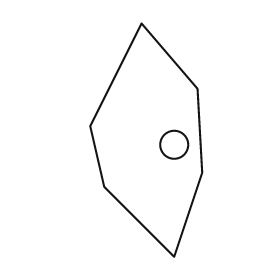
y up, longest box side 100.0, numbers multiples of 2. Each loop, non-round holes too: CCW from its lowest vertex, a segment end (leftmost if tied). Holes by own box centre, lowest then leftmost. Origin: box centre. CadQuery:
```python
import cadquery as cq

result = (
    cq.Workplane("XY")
    .moveTo(12.0, -50.0)
    .lineTo(24.0, -14.0)
    .lineTo(22.0, 22.0)
    .lineTo(-2.0, 50.0)
    .lineTo(-24.0, 6.0)
    .lineTo(-18.0, -20.0)
    .close()
    .moveTo(12.0, -2.0)
    .circle(6.0)
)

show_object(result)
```